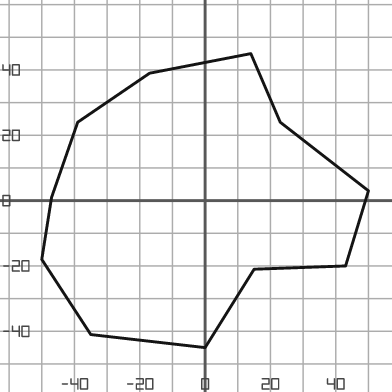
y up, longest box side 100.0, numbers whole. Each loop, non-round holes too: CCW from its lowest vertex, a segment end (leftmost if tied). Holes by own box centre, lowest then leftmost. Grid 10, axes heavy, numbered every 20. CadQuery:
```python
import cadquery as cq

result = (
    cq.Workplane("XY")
    .moveTo(0.0, -45.0)
    .lineTo(15.0, -21.0)
    .lineTo(43.0, -20.0)
    .lineTo(50.0, 3.0)
    .lineTo(23.0, 24.0)
    .lineTo(14.0, 45.0)
    .lineTo(-17.0, 39.0)
    .lineTo(-39.0, 24.0)
    .lineTo(-47.0, 1.0)
    .lineTo(-50.0, -18.0)
    .lineTo(-35.0, -41.0)
    .close()
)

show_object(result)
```